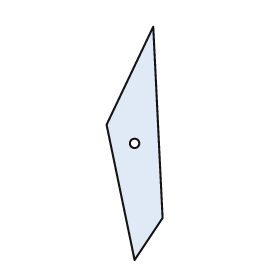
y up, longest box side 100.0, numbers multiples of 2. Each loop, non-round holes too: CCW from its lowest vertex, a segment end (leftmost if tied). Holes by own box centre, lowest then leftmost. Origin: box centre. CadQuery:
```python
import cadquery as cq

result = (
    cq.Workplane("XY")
    .moveTo(0.0, -50.0)
    .lineTo(12.0, -32.0)
    .lineTo(8.0, 50.0)
    .lineTo(-12.0, 8.0)
    .close()
    .moveTo(0.0, 0.0)
    .circle(2.0)
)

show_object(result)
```